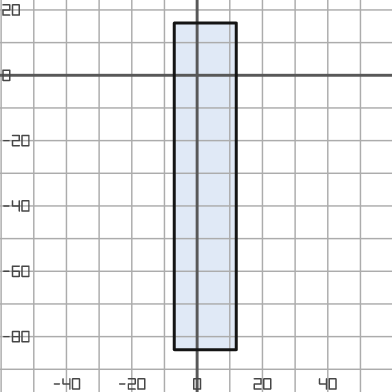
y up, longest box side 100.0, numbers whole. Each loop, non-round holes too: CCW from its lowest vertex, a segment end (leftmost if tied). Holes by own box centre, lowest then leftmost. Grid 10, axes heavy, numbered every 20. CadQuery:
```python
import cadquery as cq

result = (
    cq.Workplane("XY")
    .moveTo(-7.0, -84.0)
    .lineTo(12.0, -84.0)
    .lineTo(12.0, 16.0)
    .lineTo(-7.0, 16.0)
    .close()
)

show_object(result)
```